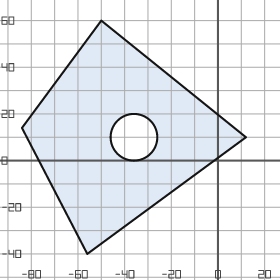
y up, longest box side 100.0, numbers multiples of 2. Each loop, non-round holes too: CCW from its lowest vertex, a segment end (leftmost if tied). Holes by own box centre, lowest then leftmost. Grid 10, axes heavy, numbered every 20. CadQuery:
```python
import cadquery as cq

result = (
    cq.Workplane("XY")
    .moveTo(-56.0, -40.0)
    .lineTo(12.0, 10.0)
    .lineTo(-50.0, 60.0)
    .lineTo(-84.0, 14.0)
    .close()
    .moveTo(-36.0, 10.0)
    .circle(10.0)
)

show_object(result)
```